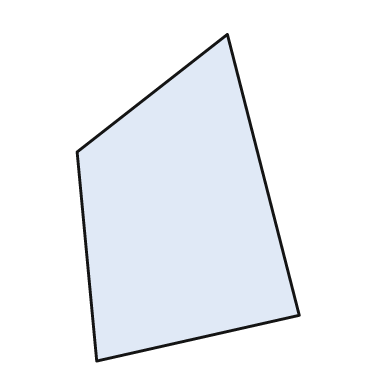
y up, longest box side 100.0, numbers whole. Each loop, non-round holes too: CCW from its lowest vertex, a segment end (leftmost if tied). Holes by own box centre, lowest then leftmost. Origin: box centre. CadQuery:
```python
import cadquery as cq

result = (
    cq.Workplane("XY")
    .moveTo(-28.0, -50.0)
    .lineTo(34.0, -36.0)
    .lineTo(12.0, 50.0)
    .lineTo(-34.0, 14.0)
    .close()
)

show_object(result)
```